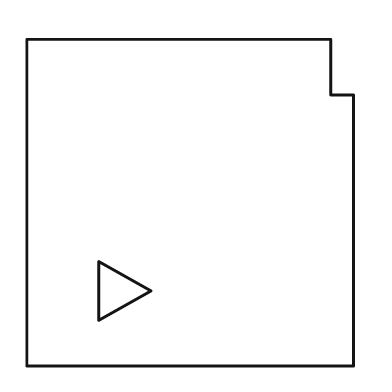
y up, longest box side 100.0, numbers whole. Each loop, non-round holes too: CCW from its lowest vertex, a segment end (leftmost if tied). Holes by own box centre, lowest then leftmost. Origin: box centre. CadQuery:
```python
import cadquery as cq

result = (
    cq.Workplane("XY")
    .moveTo(-50.0, -50.0)
    .lineTo(50.0, -50.0)
    .lineTo(50.0, 33.0)
    .lineTo(43.0, 33.0)
    .lineTo(43.0, 50.0)
    .lineTo(-50.0, 50.0)
    .close()
    .moveTo(-28.0, -36.0)
    .lineTo(-12.0, -27.0)
    .lineTo(-28.0, -18.0)
    .close()
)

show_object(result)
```